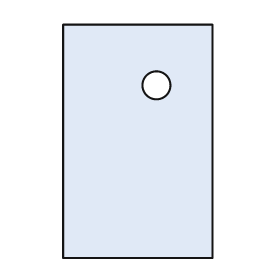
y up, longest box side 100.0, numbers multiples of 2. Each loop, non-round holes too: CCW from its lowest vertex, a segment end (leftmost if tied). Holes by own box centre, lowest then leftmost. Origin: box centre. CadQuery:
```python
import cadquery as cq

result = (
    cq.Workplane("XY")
    .moveTo(-32.0, -50.0)
    .lineTo(32.0, -50.0)
    .lineTo(32.0, 50.0)
    .lineTo(-32.0, 50.0)
    .close()
    .moveTo(8.0, 24.0)
    .circle(6.0)
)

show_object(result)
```